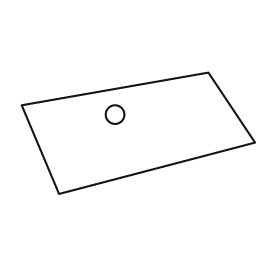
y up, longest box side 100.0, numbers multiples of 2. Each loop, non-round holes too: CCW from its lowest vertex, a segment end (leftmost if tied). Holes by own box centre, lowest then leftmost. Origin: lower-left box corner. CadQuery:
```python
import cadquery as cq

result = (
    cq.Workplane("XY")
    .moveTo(16.0, 0.0)
    .lineTo(100.0, 22.0)
    .lineTo(80.0, 52.0)
    .lineTo(0.0, 38.0)
    .close()
    .moveTo(40.0, 34.0)
    .circle(4.0)
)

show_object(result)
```